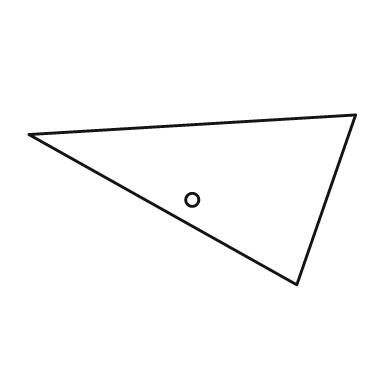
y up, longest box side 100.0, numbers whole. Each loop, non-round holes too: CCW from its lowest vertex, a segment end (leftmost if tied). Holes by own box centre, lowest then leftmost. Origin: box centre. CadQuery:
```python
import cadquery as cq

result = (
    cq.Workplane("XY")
    .moveTo(32.0, -26.0)
    .lineTo(50.0, 26.0)
    .lineTo(-50.0, 20.0)
    .close()
    .moveTo(0.0, 0.0)
    .circle(2.0)
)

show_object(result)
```